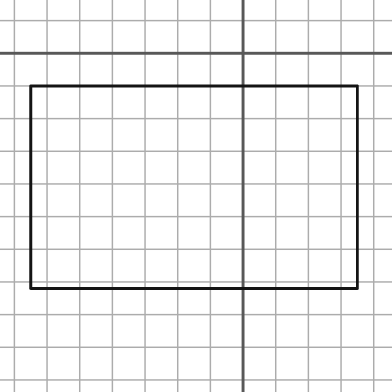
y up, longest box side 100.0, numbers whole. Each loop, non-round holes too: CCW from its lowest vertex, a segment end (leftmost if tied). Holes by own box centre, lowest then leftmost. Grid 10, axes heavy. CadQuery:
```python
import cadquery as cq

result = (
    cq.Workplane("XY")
    .moveTo(-65.0, -72.0)
    .lineTo(35.0, -72.0)
    .lineTo(35.0, -10.0)
    .lineTo(-65.0, -10.0)
    .close()
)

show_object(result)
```